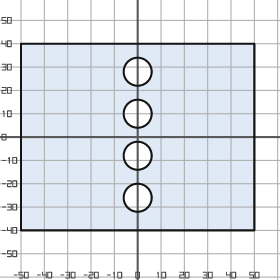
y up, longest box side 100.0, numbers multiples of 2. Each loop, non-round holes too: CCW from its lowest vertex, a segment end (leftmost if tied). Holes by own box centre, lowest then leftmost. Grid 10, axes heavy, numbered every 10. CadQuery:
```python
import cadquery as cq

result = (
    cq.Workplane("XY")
    .moveTo(-50.0, -40.0)
    .lineTo(50.0, -40.0)
    .lineTo(50.0, 40.0)
    .lineTo(-50.0, 40.0)
    .close()
    .moveTo(0.0, -26.0)
    .circle(6.0)
    .moveTo(0.0, -8.0)
    .circle(6.0)
    .moveTo(0.0, 10.0)
    .circle(6.0)
    .moveTo(0.0, 28.0)
    .circle(6.0)
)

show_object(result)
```